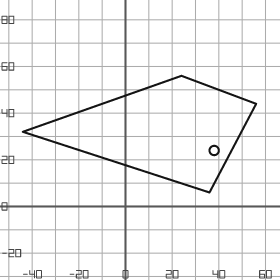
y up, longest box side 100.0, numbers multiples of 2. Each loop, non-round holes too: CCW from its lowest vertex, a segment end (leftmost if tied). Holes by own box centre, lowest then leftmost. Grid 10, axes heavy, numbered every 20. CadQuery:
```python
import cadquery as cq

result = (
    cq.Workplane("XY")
    .moveTo(36.0, 6.0)
    .lineTo(56.0, 44.0)
    .lineTo(24.0, 56.0)
    .lineTo(-44.0, 32.0)
    .close()
    .moveTo(38.0, 24.0)
    .circle(2.0)
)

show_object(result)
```